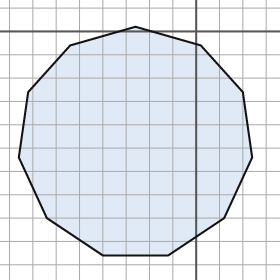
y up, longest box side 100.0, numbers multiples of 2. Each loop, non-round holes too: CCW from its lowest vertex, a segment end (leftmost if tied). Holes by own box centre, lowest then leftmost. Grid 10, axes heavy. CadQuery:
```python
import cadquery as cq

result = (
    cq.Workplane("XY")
    .moveTo(-40.0, -96.0)
    .lineTo(-12.0, -96.0)
    .lineTo(12.0, -80.0)
    .lineTo(24.0, -54.0)
    .lineTo(20.0, -26.0)
    .lineTo(2.0, -6.0)
    .lineTo(-26.0, 2.0)
    .lineTo(-54.0, -6.0)
    .lineTo(-72.0, -26.0)
    .lineTo(-76.0, -54.0)
    .lineTo(-64.0, -80.0)
    .close()
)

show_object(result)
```